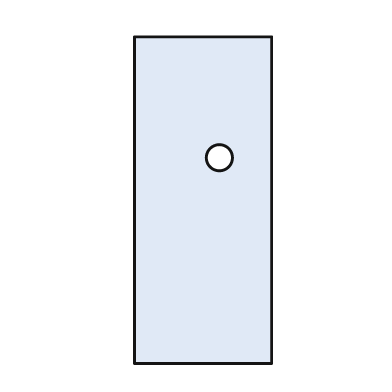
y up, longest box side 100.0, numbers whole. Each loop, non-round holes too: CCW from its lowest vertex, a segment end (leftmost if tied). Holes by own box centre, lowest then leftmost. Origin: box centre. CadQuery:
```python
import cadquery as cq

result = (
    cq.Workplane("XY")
    .moveTo(-21.0, -50.0)
    .lineTo(21.0, -50.0)
    .lineTo(21.0, 50.0)
    .lineTo(-21.0, 50.0)
    .close()
    .moveTo(5.0, 13.0)
    .circle(4.0)
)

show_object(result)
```